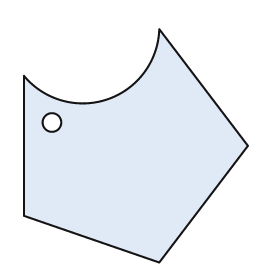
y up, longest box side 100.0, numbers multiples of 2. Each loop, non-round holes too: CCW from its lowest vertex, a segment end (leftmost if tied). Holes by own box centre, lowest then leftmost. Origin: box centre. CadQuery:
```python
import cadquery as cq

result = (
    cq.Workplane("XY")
    .moveTo(10.0, -50.0)
    .lineTo(48.0, 0.0)
    .lineTo(10.0, 50.0)
    .threePointArc((-12.0, 20.0), (-48.0, 30.0))
    .lineTo(-48.0, -30.0)
    .close()
    .moveTo(-36.0, 10.0)
    .circle(4.0)
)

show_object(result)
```